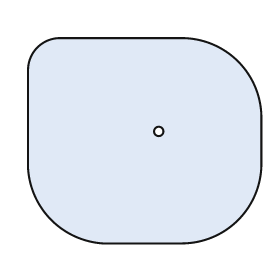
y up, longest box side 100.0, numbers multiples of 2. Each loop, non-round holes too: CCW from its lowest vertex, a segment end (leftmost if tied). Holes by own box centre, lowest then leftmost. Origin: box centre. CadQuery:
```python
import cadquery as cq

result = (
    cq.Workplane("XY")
    .moveTo(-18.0, -44.0)
    .lineTo(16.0, -44.0)
    .threePointArc((40.0, -34.0), (50.0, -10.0))
    .lineTo(50.0, 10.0)
    .threePointArc((40.0, 34.0), (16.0, 44.0))
    .lineTo(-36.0, 44.0)
    .threePointArc((-46.0, 40.0), (-50.0, 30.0))
    .lineTo(-50.0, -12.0)
    .threePointArc((-40.0, -34.0), (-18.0, -44.0))
    .close()
    .moveTo(6.0, 4.0)
    .circle(2.0)
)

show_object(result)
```